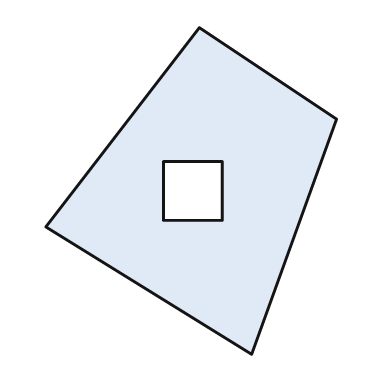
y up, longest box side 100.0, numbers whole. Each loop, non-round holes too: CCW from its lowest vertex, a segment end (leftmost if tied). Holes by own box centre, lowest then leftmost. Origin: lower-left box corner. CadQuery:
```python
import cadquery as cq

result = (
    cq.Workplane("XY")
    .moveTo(63.0, 0.0)
    .lineTo(89.0, 72.0)
    .lineTo(47.0, 100.0)
    .lineTo(0.0, 39.0)
    .close()
    .moveTo(36.0, 41.0)
    .lineTo(54.0, 41.0)
    .lineTo(54.0, 59.0)
    .lineTo(36.0, 59.0)
    .close()
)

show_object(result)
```